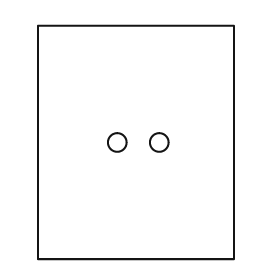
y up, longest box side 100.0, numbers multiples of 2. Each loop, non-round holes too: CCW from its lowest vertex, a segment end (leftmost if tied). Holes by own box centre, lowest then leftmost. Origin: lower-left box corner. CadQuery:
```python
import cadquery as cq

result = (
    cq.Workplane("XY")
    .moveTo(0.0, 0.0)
    .lineTo(84.0, 0.0)
    .lineTo(84.0, 100.0)
    .lineTo(0.0, 100.0)
    .close()
    .moveTo(34.0, 50.0)
    .circle(4.0)
    .moveTo(52.0, 50.0)
    .circle(4.0)
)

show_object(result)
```